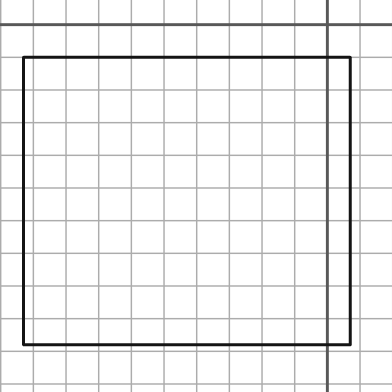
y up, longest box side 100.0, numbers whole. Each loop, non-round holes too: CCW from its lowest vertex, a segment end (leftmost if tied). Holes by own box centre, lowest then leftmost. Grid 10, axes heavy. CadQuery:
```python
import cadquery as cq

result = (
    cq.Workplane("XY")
    .moveTo(-93.0, -98.0)
    .lineTo(7.0, -98.0)
    .lineTo(7.0, -10.0)
    .lineTo(-93.0, -10.0)
    .close()
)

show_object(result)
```